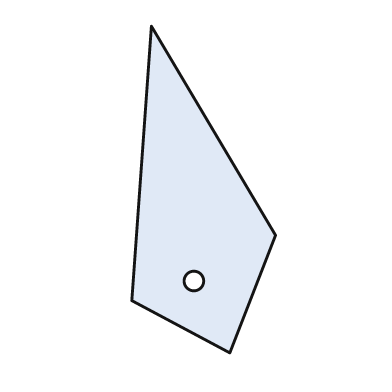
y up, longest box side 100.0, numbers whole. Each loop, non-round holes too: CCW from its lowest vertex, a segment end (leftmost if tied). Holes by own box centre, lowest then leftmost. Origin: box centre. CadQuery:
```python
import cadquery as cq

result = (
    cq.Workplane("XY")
    .moveTo(8.0, -50.0)
    .lineTo(22.0, -14.0)
    .lineTo(-16.0, 50.0)
    .lineTo(-22.0, -34.0)
    .close()
    .moveTo(-3.0, -28.0)
    .circle(3.0)
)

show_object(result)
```